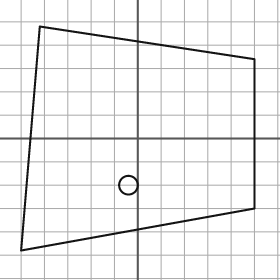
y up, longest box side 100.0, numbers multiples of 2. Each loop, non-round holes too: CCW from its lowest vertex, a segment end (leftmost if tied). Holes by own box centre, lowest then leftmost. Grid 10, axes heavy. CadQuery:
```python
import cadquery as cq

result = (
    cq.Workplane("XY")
    .moveTo(-50.0, -48.0)
    .lineTo(50.0, -30.0)
    .lineTo(50.0, 34.0)
    .lineTo(-42.0, 48.0)
    .close()
    .moveTo(-4.0, -20.0)
    .circle(4.0)
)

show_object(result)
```